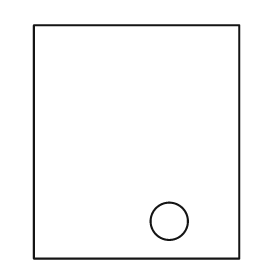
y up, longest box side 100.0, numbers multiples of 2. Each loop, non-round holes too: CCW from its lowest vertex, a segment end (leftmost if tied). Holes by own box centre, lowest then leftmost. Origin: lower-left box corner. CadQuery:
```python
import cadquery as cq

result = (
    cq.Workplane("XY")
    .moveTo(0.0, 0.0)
    .lineTo(88.0, 0.0)
    .lineTo(88.0, 100.0)
    .lineTo(0.0, 100.0)
    .close()
    .moveTo(58.0, 16.0)
    .circle(8.0)
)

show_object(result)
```